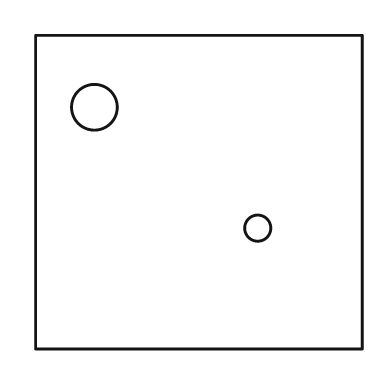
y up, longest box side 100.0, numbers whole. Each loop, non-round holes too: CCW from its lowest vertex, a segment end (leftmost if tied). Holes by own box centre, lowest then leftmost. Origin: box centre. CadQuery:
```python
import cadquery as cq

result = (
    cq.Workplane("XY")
    .moveTo(-50.0, -48.0)
    .lineTo(50.0, -48.0)
    .lineTo(50.0, 48.0)
    .lineTo(-50.0, 48.0)
    .close()
    .moveTo(18.0, -11.0)
    .circle(4.0)
    .moveTo(-32.0, 26.0)
    .circle(7.0)
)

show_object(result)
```